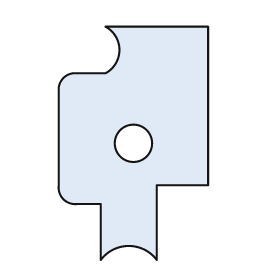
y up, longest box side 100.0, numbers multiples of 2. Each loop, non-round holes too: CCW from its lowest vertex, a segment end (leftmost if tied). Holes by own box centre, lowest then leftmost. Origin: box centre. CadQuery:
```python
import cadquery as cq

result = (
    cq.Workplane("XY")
    .moveTo(-14.0, -50.0)
    .threePointArc((-2.0, -44.0), (10.0, -50.0))
    .lineTo(10.0, -18.0)
    .lineTo(32.0, -18.0)
    .lineTo(32.0, 50.0)
    .lineTo(-12.0, 50.0)
    .threePointArc((-6.0, 40.0), (-12.0, 30.0))
    .lineTo(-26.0, 30.0)
    .threePointArc((-30.0, 28.0), (-32.0, 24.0))
    .lineTo(-32.0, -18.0)
    .threePointArc((-30.0, -24.0), (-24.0, -26.0))
    .lineTo(-14.0, -26.0)
    .close()
    .moveTo(0.0, 0.0)
    .circle(8.0)
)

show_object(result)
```